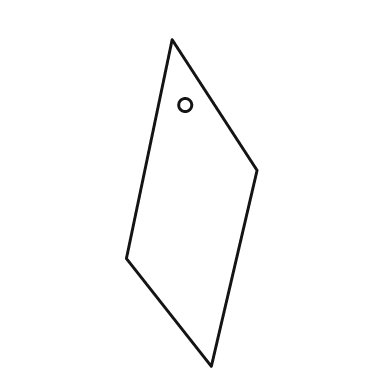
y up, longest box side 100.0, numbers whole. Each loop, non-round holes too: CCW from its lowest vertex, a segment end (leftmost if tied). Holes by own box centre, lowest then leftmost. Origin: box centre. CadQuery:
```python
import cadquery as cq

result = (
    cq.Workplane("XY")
    .moveTo(6.0, -50.0)
    .lineTo(20.0, 10.0)
    .lineTo(-6.0, 50.0)
    .lineTo(-20.0, -17.0)
    .close()
    .moveTo(-2.0, 30.0)
    .circle(2.0)
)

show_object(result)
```